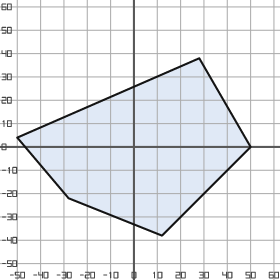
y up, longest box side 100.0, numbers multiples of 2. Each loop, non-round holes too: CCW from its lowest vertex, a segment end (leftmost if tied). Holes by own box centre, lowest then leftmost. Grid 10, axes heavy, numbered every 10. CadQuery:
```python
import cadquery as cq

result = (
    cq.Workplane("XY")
    .moveTo(12.0, -38.0)
    .lineTo(50.0, 0.0)
    .lineTo(28.0, 38.0)
    .lineTo(-50.0, 4.0)
    .lineTo(-28.0, -22.0)
    .close()
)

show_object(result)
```